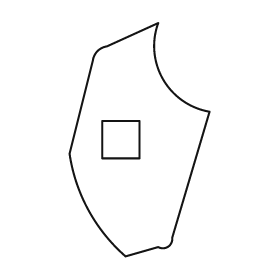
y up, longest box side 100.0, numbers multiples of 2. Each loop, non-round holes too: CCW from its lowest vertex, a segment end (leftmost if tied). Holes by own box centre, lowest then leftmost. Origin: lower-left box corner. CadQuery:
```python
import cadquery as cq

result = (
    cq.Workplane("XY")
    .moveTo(24.0, 0.0)
    .lineTo(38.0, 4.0)
    .threePointArc((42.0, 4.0), (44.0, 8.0))
    .lineTo(60.0, 62.0)
    .threePointArc((40.0, 76.0), (38.0, 100.0))
    .lineTo(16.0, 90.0)
    .threePointArc((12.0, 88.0), (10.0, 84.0))
    .lineTo(0.0, 44.0)
    .threePointArc((8.0, 20.0), (24.0, 0.0))
    .close()
    .moveTo(14.0, 42.0)
    .lineTo(30.0, 42.0)
    .lineTo(30.0, 58.0)
    .lineTo(14.0, 58.0)
    .close()
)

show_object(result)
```